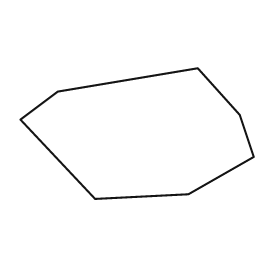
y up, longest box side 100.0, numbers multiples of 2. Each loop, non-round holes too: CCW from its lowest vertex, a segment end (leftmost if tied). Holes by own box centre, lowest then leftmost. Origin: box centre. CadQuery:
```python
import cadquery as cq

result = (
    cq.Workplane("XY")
    .moveTo(-18.0, -28.0)
    .lineTo(22.0, -26.0)
    .lineTo(50.0, -10.0)
    .lineTo(44.0, 8.0)
    .lineTo(26.0, 28.0)
    .lineTo(-34.0, 18.0)
    .lineTo(-50.0, 6.0)
    .close()
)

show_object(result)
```